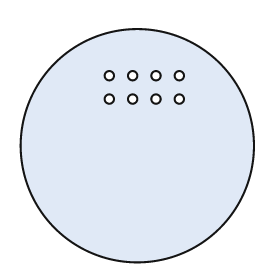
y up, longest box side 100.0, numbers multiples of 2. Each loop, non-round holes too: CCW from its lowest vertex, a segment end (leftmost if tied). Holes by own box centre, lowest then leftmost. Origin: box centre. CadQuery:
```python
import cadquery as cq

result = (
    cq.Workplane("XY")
    .moveTo(0.0, 0.0)
    .circle(50.0)
    .moveTo(-12.0, 20.0)
    .circle(2.0)
    .moveTo(-2.0, 20.0)
    .circle(2.0)
    .moveTo(8.0, 20.0)
    .circle(2.0)
    .moveTo(18.0, 20.0)
    .circle(2.0)
    .moveTo(-12.0, 30.0)
    .circle(2.0)
    .moveTo(-2.0, 30.0)
    .circle(2.0)
    .moveTo(8.0, 30.0)
    .circle(2.0)
    .moveTo(18.0, 30.0)
    .circle(2.0)
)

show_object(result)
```